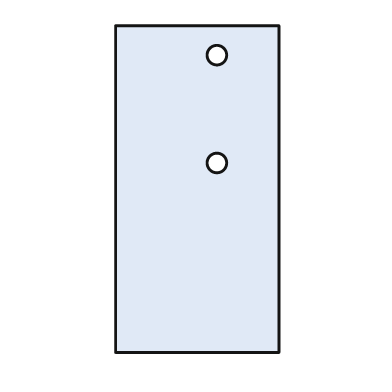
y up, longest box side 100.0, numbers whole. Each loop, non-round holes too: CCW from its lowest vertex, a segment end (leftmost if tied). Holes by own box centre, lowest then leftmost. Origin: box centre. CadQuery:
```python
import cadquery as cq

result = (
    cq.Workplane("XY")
    .moveTo(-25.0, -50.0)
    .lineTo(25.0, -50.0)
    .lineTo(25.0, 50.0)
    .lineTo(-25.0, 50.0)
    .close()
    .moveTo(6.0, 8.0)
    .circle(3.0)
    .moveTo(6.0, 41.0)
    .circle(3.0)
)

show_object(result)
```